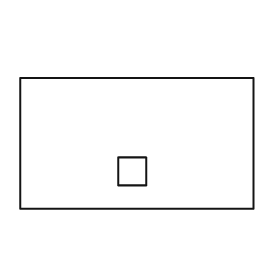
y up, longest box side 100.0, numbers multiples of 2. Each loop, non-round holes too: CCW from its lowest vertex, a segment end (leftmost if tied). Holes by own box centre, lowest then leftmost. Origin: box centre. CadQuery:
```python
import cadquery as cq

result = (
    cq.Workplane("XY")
    .moveTo(-50.0, -28.0)
    .lineTo(50.0, -28.0)
    .lineTo(50.0, 28.0)
    .lineTo(-50.0, 28.0)
    .close()
    .moveTo(-8.0, -18.0)
    .lineTo(4.0, -18.0)
    .lineTo(4.0, -6.0)
    .lineTo(-8.0, -6.0)
    .close()
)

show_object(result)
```